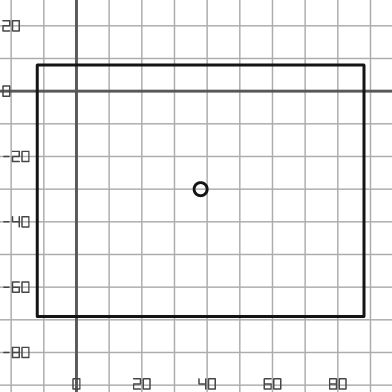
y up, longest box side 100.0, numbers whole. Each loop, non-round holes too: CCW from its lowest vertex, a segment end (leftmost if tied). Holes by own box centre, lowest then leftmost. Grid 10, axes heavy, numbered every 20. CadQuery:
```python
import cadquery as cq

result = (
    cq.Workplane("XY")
    .moveTo(-12.0, -69.0)
    .lineTo(88.0, -69.0)
    .lineTo(88.0, 8.0)
    .lineTo(-12.0, 8.0)
    .close()
    .moveTo(38.0, -30.0)
    .circle(2.0)
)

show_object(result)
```